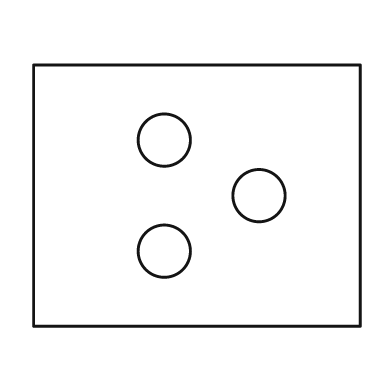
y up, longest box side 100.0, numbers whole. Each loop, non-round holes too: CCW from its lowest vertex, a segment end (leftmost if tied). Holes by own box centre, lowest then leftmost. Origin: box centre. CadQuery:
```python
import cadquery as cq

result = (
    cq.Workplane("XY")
    .moveTo(-50.0, -40.0)
    .lineTo(50.0, -40.0)
    .lineTo(50.0, 40.0)
    .lineTo(-50.0, 40.0)
    .close()
    .moveTo(-10.0, -17.0)
    .circle(8.0)
    .moveTo(19.0, 0.0)
    .circle(8.0)
    .moveTo(-10.0, 17.0)
    .circle(8.0)
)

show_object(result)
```